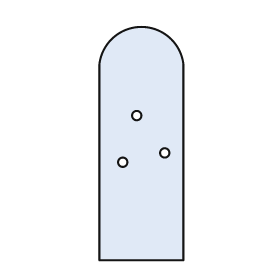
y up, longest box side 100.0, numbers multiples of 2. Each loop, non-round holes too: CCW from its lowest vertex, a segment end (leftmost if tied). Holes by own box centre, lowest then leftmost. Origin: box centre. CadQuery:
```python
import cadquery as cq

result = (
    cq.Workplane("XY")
    .moveTo(-18.0, -50.0)
    .lineTo(18.0, -50.0)
    .lineTo(18.0, 34.0)
    .threePointArc((0.0, 50.0), (-18.0, 34.0))
    .close()
    .moveTo(-8.0, -8.0)
    .circle(2.0)
    .moveTo(10.0, -4.0)
    .circle(2.0)
    .moveTo(-2.0, 12.0)
    .circle(2.0)
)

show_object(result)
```